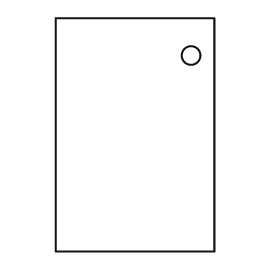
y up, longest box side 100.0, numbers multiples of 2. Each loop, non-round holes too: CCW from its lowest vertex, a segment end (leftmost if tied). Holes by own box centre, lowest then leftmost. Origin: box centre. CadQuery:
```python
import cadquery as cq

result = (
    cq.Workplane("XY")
    .moveTo(-34.0, -50.0)
    .lineTo(34.0, -50.0)
    .lineTo(34.0, 50.0)
    .lineTo(-34.0, 50.0)
    .close()
    .moveTo(24.0, 34.0)
    .circle(4.0)
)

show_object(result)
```